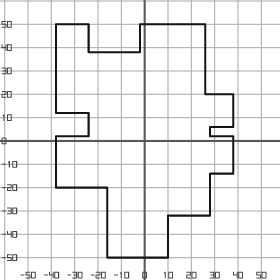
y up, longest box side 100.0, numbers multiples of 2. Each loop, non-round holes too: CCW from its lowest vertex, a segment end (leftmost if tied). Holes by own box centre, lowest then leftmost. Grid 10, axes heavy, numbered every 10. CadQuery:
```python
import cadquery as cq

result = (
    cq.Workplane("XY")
    .moveTo(-16.0, -50.0)
    .lineTo(10.0, -50.0)
    .lineTo(10.0, -32.0)
    .lineTo(28.0, -32.0)
    .lineTo(28.0, -14.0)
    .lineTo(38.0, -14.0)
    .lineTo(38.0, 2.0)
    .lineTo(28.0, 2.0)
    .lineTo(28.0, 6.0)
    .lineTo(38.0, 6.0)
    .lineTo(38.0, 20.0)
    .lineTo(26.0, 20.0)
    .lineTo(26.0, 50.0)
    .lineTo(-2.0, 50.0)
    .lineTo(-2.0, 38.0)
    .lineTo(-24.0, 38.0)
    .lineTo(-24.0, 50.0)
    .lineTo(-38.0, 50.0)
    .lineTo(-38.0, 12.0)
    .lineTo(-24.0, 12.0)
    .lineTo(-24.0, 2.0)
    .lineTo(-38.0, 2.0)
    .lineTo(-38.0, -20.0)
    .lineTo(-16.0, -20.0)
    .close()
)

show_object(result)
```